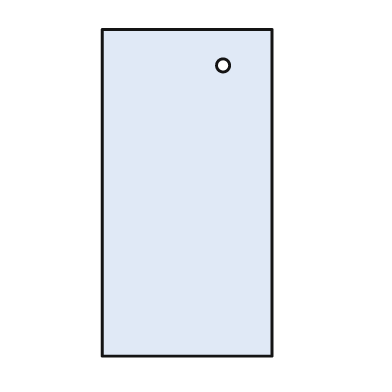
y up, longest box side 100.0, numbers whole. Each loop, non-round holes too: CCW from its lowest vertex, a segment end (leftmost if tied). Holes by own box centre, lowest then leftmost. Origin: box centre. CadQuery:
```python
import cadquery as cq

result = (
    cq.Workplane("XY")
    .moveTo(-26.0, -50.0)
    .lineTo(26.0, -50.0)
    .lineTo(26.0, 50.0)
    .lineTo(-26.0, 50.0)
    .close()
    .moveTo(11.0, 39.0)
    .circle(2.0)
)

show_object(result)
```